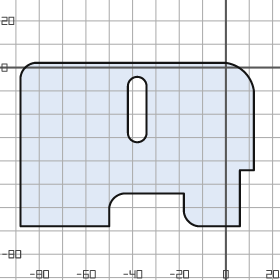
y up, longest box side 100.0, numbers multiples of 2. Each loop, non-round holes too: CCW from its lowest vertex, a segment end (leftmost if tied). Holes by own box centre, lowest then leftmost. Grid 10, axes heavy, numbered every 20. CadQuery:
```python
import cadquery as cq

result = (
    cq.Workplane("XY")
    .moveTo(-88.0, -68.0)
    .lineTo(-50.0, -68.0)
    .lineTo(-50.0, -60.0)
    .threePointArc((-48.0, -56.0), (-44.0, -54.0))
    .lineTo(-18.0, -54.0)
    .lineTo(-18.0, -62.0)
    .threePointArc((-16.0, -66.0), (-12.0, -68.0))
    .lineTo(6.0, -68.0)
    .lineTo(6.0, -44.0)
    .lineTo(12.0, -44.0)
    .lineTo(12.0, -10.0)
    .threePointArc((8.0, -2.0), (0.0, 2.0))
    .lineTo(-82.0, 2.0)
    .threePointArc((-86.0, 0.0), (-88.0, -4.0))
    .close()
    .moveTo(-42.0, -28.0)
    .threePointArc((-38.0, -32.0), (-34.0, -28.0))
    .lineTo(-34.0, -8.0)
    .threePointArc((-38.0, -4.0), (-42.0, -8.0))
    .close()
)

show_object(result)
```